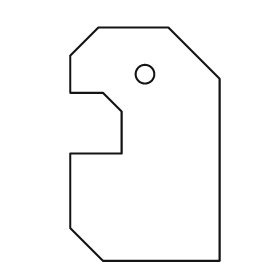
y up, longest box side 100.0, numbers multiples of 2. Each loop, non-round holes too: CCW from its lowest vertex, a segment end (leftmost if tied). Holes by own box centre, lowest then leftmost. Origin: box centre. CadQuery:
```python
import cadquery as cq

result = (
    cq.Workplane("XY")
    .moveTo(-18.0, -50.0)
    .lineTo(32.0, -50.0)
    .lineTo(32.0, 28.0)
    .lineTo(10.0, 50.0)
    .lineTo(-20.0, 50.0)
    .lineTo(-32.0, 38.0)
    .lineTo(-32.0, 22.0)
    .lineTo(-18.0, 22.0)
    .lineTo(-10.0, 14.0)
    .lineTo(-10.0, -4.0)
    .lineTo(-32.0, -4.0)
    .lineTo(-32.0, -36.0)
    .close()
    .moveTo(0.0, 30.0)
    .circle(4.0)
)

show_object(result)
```